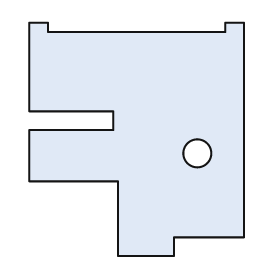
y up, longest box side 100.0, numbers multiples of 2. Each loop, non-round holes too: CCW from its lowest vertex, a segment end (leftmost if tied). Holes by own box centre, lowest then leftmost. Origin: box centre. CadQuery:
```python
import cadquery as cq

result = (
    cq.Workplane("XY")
    .moveTo(-8.0, -50.0)
    .lineTo(16.0, -50.0)
    .lineTo(16.0, -42.0)
    .lineTo(46.0, -42.0)
    .lineTo(46.0, 50.0)
    .lineTo(38.0, 50.0)
    .lineTo(38.0, 46.0)
    .lineTo(-38.0, 46.0)
    .lineTo(-38.0, 50.0)
    .lineTo(-46.0, 50.0)
    .lineTo(-46.0, 12.0)
    .lineTo(-10.0, 12.0)
    .lineTo(-10.0, 4.0)
    .lineTo(-46.0, 4.0)
    .lineTo(-46.0, -18.0)
    .lineTo(-8.0, -18.0)
    .close()
    .moveTo(26.0, -6.0)
    .circle(6.0)
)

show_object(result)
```